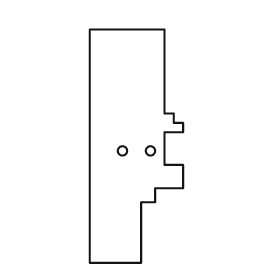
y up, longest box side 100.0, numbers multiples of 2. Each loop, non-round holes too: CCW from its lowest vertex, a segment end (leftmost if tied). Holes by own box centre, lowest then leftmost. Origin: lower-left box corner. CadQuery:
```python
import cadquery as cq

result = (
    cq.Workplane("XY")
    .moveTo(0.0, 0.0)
    .lineTo(22.0, 0.0)
    .lineTo(22.0, 26.0)
    .lineTo(28.0, 26.0)
    .lineTo(28.0, 32.0)
    .lineTo(40.0, 32.0)
    .lineTo(40.0, 42.0)
    .lineTo(32.0, 42.0)
    .lineTo(32.0, 56.0)
    .lineTo(40.0, 56.0)
    .lineTo(40.0, 60.0)
    .lineTo(36.0, 60.0)
    .lineTo(36.0, 64.0)
    .lineTo(32.0, 64.0)
    .lineTo(32.0, 100.0)
    .lineTo(0.0, 100.0)
    .close()
    .moveTo(14.0, 48.0)
    .circle(2.0)
    .moveTo(26.0, 48.0)
    .circle(2.0)
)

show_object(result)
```